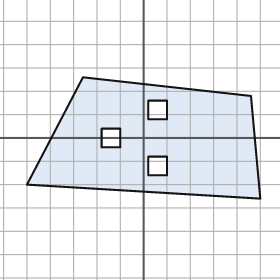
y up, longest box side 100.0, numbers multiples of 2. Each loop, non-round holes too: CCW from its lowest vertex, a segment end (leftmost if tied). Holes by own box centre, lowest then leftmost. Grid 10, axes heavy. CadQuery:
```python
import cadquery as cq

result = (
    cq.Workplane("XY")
    .moveTo(50.0, -26.0)
    .lineTo(46.0, 18.0)
    .lineTo(-26.0, 26.0)
    .lineTo(-50.0, -20.0)
    .close()
    .moveTo(2.0, -16.0)
    .lineTo(10.0, -16.0)
    .lineTo(10.0, -8.0)
    .lineTo(2.0, -8.0)
    .close()
    .moveTo(-18.0, -4.0)
    .lineTo(-10.0, -4.0)
    .lineTo(-10.0, 4.0)
    .lineTo(-18.0, 4.0)
    .close()
    .moveTo(2.0, 8.0)
    .lineTo(10.0, 8.0)
    .lineTo(10.0, 16.0)
    .lineTo(2.0, 16.0)
    .close()
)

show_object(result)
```